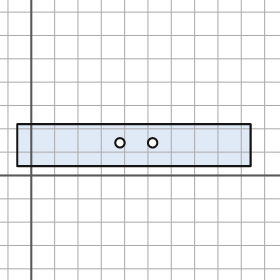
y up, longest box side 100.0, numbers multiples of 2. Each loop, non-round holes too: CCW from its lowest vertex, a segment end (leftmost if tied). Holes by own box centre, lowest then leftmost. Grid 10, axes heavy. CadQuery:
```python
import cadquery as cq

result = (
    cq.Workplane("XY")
    .moveTo(-6.0, 4.0)
    .lineTo(94.0, 4.0)
    .lineTo(94.0, 22.0)
    .lineTo(-6.0, 22.0)
    .close()
    .moveTo(38.0, 14.0)
    .circle(2.0)
    .moveTo(52.0, 14.0)
    .circle(2.0)
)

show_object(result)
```